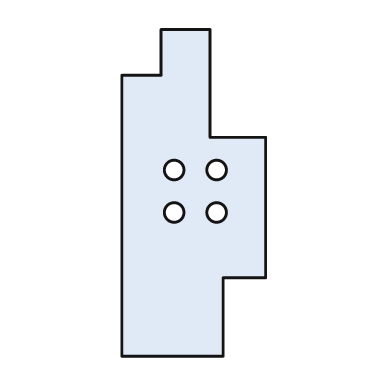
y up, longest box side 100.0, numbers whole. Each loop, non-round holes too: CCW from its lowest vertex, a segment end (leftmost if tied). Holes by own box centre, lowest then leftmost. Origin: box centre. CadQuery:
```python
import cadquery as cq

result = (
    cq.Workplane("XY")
    .moveTo(-22.0, -50.0)
    .lineTo(9.0, -50.0)
    .lineTo(9.0, -26.0)
    .lineTo(22.0, -26.0)
    .lineTo(22.0, 17.0)
    .lineTo(5.0, 17.0)
    .lineTo(5.0, 50.0)
    .lineTo(-10.0, 50.0)
    .lineTo(-10.0, 36.0)
    .lineTo(-22.0, 36.0)
    .close()
    .moveTo(-6.0, -6.0)
    .circle(3.0)
    .moveTo(7.0, -6.0)
    .circle(3.0)
    .moveTo(-6.0, 7.0)
    .circle(3.0)
    .moveTo(7.0, 7.0)
    .circle(3.0)
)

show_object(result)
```